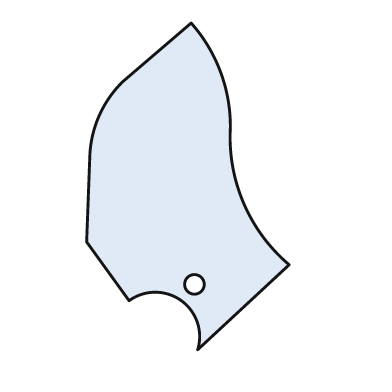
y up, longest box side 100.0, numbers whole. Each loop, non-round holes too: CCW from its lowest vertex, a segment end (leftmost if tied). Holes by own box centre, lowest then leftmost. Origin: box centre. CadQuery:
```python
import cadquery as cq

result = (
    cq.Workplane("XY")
    .moveTo(3.0, -50.0)
    .lineTo(31.0, -24.0)
    .threePointArc((17.0, -5.0), (13.0, 18.0))
    .threePointArc((10.0, 35.0), (1.0, 50.0))
    .lineTo(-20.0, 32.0)
    .threePointArc((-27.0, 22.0), (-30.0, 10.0))
    .lineTo(-31.0, -17.0)
    .lineTo(-18.0, -35.0)
    .threePointArc((-2.0, -35.0), (3.0, -50.0))
    .close()
    .moveTo(2.0, -30.0)
    .circle(3.0)
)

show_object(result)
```